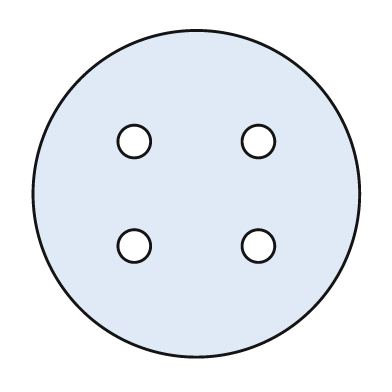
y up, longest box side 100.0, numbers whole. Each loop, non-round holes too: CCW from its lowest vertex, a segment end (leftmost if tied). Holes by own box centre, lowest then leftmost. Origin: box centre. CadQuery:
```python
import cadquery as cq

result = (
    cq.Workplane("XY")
    .moveTo(0.0, 0.0)
    .circle(50.0)
    .moveTo(-19.0, -16.0)
    .circle(5.0)
    .moveTo(19.0, -16.0)
    .circle(5.0)
    .moveTo(-19.0, 16.0)
    .circle(5.0)
    .moveTo(19.0, 16.0)
    .circle(5.0)
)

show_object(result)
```